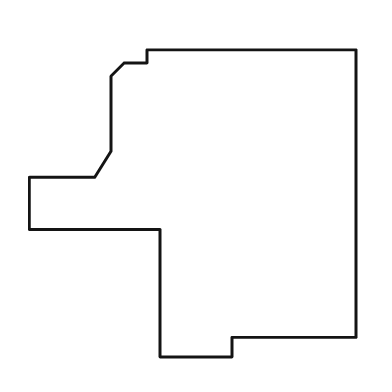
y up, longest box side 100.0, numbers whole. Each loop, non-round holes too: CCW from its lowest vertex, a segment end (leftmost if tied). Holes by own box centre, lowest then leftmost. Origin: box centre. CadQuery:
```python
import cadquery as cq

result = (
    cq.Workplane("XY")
    .moveTo(-10.0, -47.0)
    .lineTo(12.0, -47.0)
    .lineTo(12.0, -41.0)
    .lineTo(50.0, -41.0)
    .lineTo(50.0, 47.0)
    .lineTo(-14.0, 47.0)
    .lineTo(-14.0, 43.0)
    .lineTo(-21.0, 43.0)
    .lineTo(-25.0, 39.0)
    .lineTo(-25.0, 16.0)
    .lineTo(-30.0, 8.0)
    .lineTo(-50.0, 8.0)
    .lineTo(-50.0, -8.0)
    .lineTo(-10.0, -8.0)
    .close()
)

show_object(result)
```